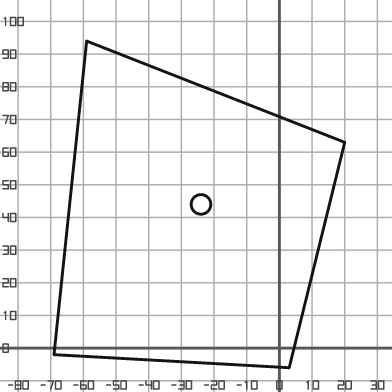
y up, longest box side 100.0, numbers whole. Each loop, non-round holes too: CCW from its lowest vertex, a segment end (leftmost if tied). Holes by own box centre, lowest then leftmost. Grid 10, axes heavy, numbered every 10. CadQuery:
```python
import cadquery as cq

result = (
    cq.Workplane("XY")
    .moveTo(3.0, -6.0)
    .lineTo(20.0, 63.0)
    .lineTo(-59.0, 94.0)
    .lineTo(-69.0, -2.0)
    .close()
    .moveTo(-24.0, 44.0)
    .circle(3.0)
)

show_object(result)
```